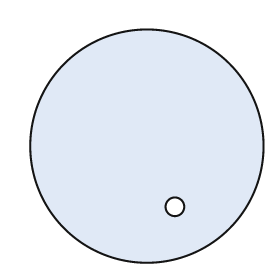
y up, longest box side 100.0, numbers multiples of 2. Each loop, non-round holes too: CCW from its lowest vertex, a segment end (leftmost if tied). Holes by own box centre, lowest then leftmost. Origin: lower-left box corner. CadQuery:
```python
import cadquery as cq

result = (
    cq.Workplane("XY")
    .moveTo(50.0, 50.0)
    .circle(50.0)
    .moveTo(62.0, 24.0)
    .circle(4.0)
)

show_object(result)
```